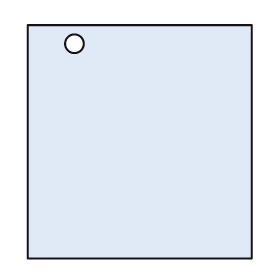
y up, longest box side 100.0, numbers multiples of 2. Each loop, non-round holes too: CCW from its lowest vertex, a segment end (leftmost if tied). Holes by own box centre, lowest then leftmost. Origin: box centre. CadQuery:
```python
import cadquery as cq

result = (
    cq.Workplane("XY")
    .moveTo(-48.0, -50.0)
    .lineTo(48.0, -50.0)
    .lineTo(48.0, 50.0)
    .lineTo(-48.0, 50.0)
    .close()
    .moveTo(-28.0, 42.0)
    .circle(4.0)
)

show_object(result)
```